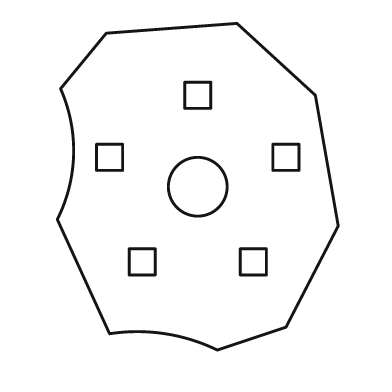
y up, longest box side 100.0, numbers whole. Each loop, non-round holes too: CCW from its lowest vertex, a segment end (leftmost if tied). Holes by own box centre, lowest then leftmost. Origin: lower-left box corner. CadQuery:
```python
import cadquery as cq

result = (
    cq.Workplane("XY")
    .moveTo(49.0, 0.0)
    .lineTo(70.0, 7.0)
    .lineTo(86.0, 38.0)
    .lineTo(79.0, 78.0)
    .lineTo(55.0, 100.0)
    .lineTo(15.0, 97.0)
    .lineTo(1.0, 80.0)
    .threePointArc((5.0, 60.0), (0.0, 40.0))
    .lineTo(16.0, 5.0)
    .threePointArc((33.0, 5.0), (49.0, 0.0))
    .close()
    .moveTo(22.0, 23.0)
    .lineTo(30.0, 23.0)
    .lineTo(30.0, 31.0)
    .lineTo(22.0, 31.0)
    .close()
    .moveTo(56.0, 23.0)
    .lineTo(64.0, 23.0)
    .lineTo(64.0, 31.0)
    .lineTo(56.0, 31.0)
    .close()
    .moveTo(43.0, 50.0)
    .circle(9.0)
    .moveTo(12.0, 55.0)
    .lineTo(20.0, 55.0)
    .lineTo(20.0, 63.0)
    .lineTo(12.0, 63.0)
    .close()
    .moveTo(66.0, 55.0)
    .lineTo(74.0, 55.0)
    .lineTo(74.0, 63.0)
    .lineTo(66.0, 63.0)
    .close()
    .moveTo(39.0, 74.0)
    .lineTo(47.0, 74.0)
    .lineTo(47.0, 82.0)
    .lineTo(39.0, 82.0)
    .close()
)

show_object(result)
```